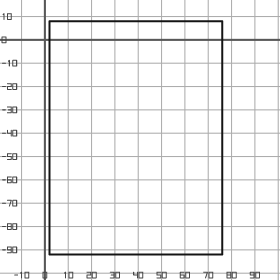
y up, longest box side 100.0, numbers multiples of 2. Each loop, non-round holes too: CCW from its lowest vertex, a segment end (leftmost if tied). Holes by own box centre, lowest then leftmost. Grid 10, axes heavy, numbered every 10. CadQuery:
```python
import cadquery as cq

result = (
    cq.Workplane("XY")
    .moveTo(2.0, -92.0)
    .lineTo(76.0, -92.0)
    .lineTo(76.0, 8.0)
    .lineTo(2.0, 8.0)
    .close()
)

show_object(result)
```